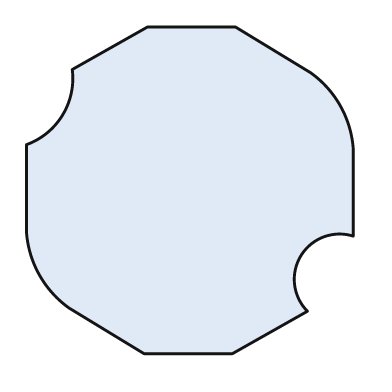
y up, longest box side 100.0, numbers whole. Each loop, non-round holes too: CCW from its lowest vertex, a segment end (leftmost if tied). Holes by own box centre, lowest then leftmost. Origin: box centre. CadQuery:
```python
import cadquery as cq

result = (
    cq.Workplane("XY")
    .moveTo(-14.0, -50.0)
    .lineTo(13.0, -50.0)
    .lineTo(36.0, -37.0)
    .threePointArc((34.0, -20.0), (50.0, -14.0))
    .lineTo(50.0, 13.0)
    .threePointArc((46.0, 26.0), (37.0, 36.0))
    .lineTo(14.0, 50.0)
    .lineTo(-13.0, 50.0)
    .lineTo(-36.0, 37.0)
    .threePointArc((-39.0, 23.0), (-50.0, 14.0))
    .lineTo(-50.0, -13.0)
    .threePointArc((-46.0, -26.0), (-37.0, -36.0))
    .close()
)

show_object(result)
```